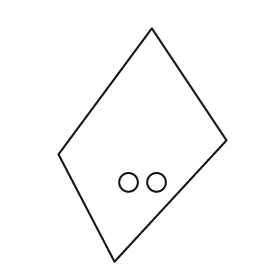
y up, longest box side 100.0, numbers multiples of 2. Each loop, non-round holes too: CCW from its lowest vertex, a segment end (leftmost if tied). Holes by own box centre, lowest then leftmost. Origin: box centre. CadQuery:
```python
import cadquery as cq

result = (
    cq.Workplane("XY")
    .moveTo(-12.0, -50.0)
    .lineTo(36.0, 2.0)
    .lineTo(4.0, 50.0)
    .lineTo(-36.0, -4.0)
    .close()
    .moveTo(-6.0, -16.0)
    .circle(4.0)
    .moveTo(6.0, -16.0)
    .circle(4.0)
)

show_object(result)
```